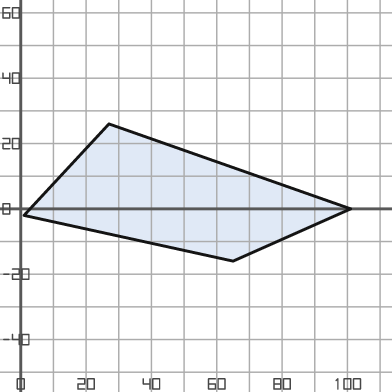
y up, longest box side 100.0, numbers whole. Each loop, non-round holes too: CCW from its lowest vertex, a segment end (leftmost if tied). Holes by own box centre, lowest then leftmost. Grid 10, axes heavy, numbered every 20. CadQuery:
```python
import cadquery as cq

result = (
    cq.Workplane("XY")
    .moveTo(65.0, -16.0)
    .lineTo(101.0, 0.0)
    .lineTo(27.0, 26.0)
    .lineTo(1.0, -2.0)
    .close()
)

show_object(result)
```